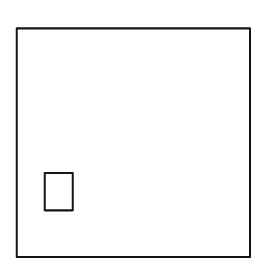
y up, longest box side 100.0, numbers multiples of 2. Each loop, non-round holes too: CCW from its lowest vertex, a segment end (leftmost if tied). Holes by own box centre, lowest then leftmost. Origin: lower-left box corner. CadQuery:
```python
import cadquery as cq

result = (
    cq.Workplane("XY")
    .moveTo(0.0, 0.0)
    .lineTo(100.0, 0.0)
    .lineTo(100.0, 98.0)
    .lineTo(0.0, 98.0)
    .close()
    .moveTo(12.0, 20.0)
    .lineTo(24.0, 20.0)
    .lineTo(24.0, 36.0)
    .lineTo(12.0, 36.0)
    .close()
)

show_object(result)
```